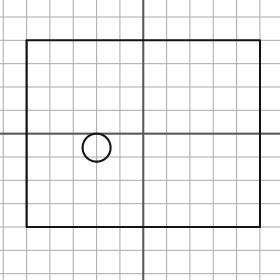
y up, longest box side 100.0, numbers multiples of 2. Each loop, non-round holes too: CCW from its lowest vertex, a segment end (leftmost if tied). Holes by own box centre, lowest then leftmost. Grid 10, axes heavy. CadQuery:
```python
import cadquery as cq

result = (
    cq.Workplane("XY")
    .moveTo(-50.0, -40.0)
    .lineTo(50.0, -40.0)
    .lineTo(50.0, 40.0)
    .lineTo(-50.0, 40.0)
    .close()
    .moveTo(-20.0, -6.0)
    .circle(6.0)
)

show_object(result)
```